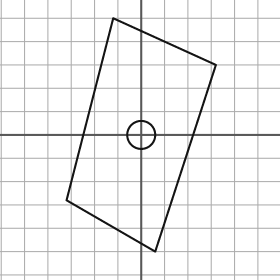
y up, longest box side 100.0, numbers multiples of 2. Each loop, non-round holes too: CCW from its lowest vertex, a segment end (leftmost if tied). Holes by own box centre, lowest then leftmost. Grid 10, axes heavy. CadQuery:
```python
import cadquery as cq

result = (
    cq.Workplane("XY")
    .moveTo(6.0, -50.0)
    .lineTo(32.0, 30.0)
    .lineTo(-12.0, 50.0)
    .lineTo(-32.0, -28.0)
    .close()
    .moveTo(0.0, 0.0)
    .circle(6.0)
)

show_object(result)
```